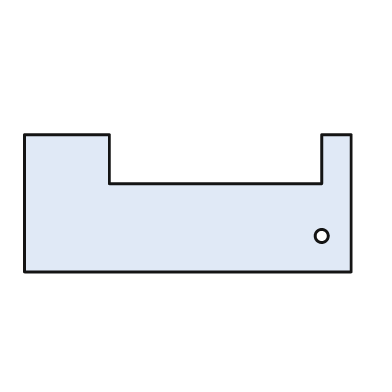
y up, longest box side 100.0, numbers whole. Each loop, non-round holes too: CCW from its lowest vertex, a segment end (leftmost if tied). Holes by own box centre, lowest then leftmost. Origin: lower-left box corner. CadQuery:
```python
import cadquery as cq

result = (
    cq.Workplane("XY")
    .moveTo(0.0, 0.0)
    .lineTo(100.0, 0.0)
    .lineTo(100.0, 42.0)
    .lineTo(91.0, 42.0)
    .lineTo(91.0, 27.0)
    .lineTo(26.0, 27.0)
    .lineTo(26.0, 42.0)
    .lineTo(0.0, 42.0)
    .close()
    .moveTo(91.0, 11.0)
    .circle(2.0)
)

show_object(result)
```